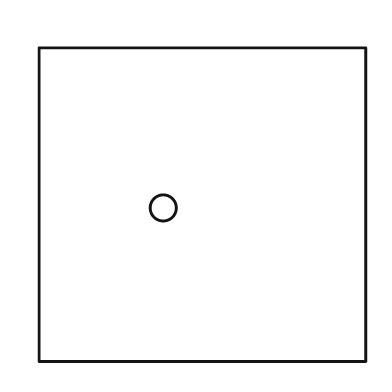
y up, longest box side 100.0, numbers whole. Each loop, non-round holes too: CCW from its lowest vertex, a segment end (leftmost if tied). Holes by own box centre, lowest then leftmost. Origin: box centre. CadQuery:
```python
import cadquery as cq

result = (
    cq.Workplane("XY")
    .moveTo(-50.0, -48.0)
    .lineTo(50.0, -48.0)
    .lineTo(50.0, 48.0)
    .lineTo(-50.0, 48.0)
    .close()
    .moveTo(-12.0, -1.0)
    .circle(4.0)
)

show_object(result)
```